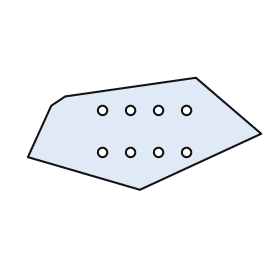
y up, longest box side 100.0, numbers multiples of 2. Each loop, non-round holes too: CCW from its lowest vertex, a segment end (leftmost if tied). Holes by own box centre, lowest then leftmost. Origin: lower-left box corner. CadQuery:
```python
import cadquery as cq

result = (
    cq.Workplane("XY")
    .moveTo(48.0, 0.0)
    .lineTo(100.0, 24.0)
    .lineTo(72.0, 48.0)
    .lineTo(16.0, 40.0)
    .lineTo(10.0, 36.0)
    .lineTo(0.0, 14.0)
    .close()
    .moveTo(32.0, 16.0)
    .circle(2.0)
    .moveTo(44.0, 16.0)
    .circle(2.0)
    .moveTo(56.0, 16.0)
    .circle(2.0)
    .moveTo(68.0, 16.0)
    .circle(2.0)
    .moveTo(32.0, 34.0)
    .circle(2.0)
    .moveTo(44.0, 34.0)
    .circle(2.0)
    .moveTo(56.0, 34.0)
    .circle(2.0)
    .moveTo(68.0, 34.0)
    .circle(2.0)
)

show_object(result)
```